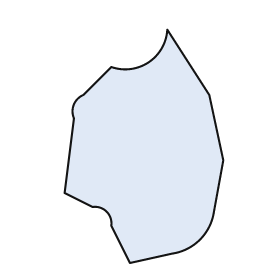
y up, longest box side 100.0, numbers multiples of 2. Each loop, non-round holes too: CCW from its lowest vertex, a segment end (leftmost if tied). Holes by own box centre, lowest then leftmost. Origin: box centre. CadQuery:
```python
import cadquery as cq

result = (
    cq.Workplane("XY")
    .moveTo(-6.0, -50.0)
    .lineTo(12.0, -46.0)
    .threePointArc((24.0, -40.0), (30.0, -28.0))
    .lineTo(34.0, -6.0)
    .lineTo(28.0, 22.0)
    .lineTo(10.0, 50.0)
    .threePointArc((2.0, 36.0), (-14.0, 34.0))
    .lineTo(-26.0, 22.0)
    .threePointArc((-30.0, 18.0), (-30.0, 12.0))
    .lineTo(-34.0, -20.0)
    .lineTo(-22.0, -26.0)
    .threePointArc((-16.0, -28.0), (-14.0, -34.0))
    .close()
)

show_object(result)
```